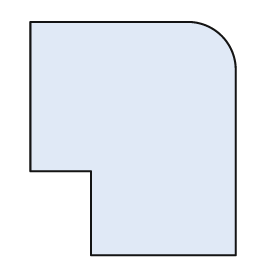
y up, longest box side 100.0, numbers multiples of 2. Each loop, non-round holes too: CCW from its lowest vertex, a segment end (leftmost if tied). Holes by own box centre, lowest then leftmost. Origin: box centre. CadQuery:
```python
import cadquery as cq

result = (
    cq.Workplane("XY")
    .moveTo(-18.0, -50.0)
    .lineTo(44.0, -50.0)
    .lineTo(44.0, 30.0)
    .threePointArc((38.0, 44.0), (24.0, 50.0))
    .lineTo(-44.0, 50.0)
    .lineTo(-44.0, -14.0)
    .lineTo(-18.0, -14.0)
    .close()
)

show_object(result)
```